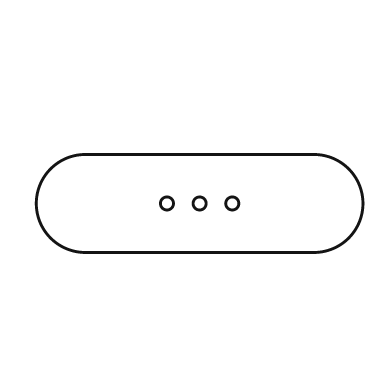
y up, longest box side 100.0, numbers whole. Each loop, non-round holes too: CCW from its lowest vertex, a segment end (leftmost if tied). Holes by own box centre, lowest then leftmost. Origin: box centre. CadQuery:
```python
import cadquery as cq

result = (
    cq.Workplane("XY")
    .moveTo(-35.0, -15.0)
    .lineTo(35.0, -15.0)
    .threePointArc((50.0, 0.0), (35.0, 15.0))
    .lineTo(-35.0, 15.0)
    .threePointArc((-50.0, 0.0), (-35.0, -15.0))
    .close()
    .moveTo(-10.0, 0.0)
    .circle(2.0)
    .moveTo(0.0, 0.0)
    .circle(2.0)
    .moveTo(10.0, 0.0)
    .circle(2.0)
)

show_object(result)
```